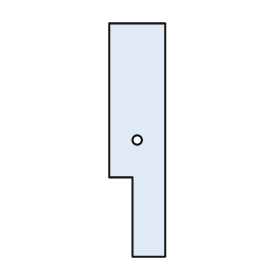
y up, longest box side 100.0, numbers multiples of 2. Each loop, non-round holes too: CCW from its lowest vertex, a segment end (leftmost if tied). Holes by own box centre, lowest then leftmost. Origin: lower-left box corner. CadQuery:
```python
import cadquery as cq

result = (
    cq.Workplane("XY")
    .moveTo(10.0, 0.0)
    .lineTo(24.0, 0.0)
    .lineTo(24.0, 100.0)
    .lineTo(0.0, 100.0)
    .lineTo(0.0, 34.0)
    .lineTo(10.0, 34.0)
    .close()
    .moveTo(12.0, 50.0)
    .circle(2.0)
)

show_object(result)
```